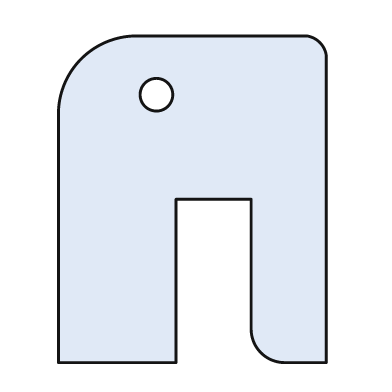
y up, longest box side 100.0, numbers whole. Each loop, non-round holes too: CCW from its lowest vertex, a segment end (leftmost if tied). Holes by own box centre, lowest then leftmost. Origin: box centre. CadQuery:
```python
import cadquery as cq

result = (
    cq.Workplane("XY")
    .moveTo(-41.0, -50.0)
    .lineTo(-5.0, -50.0)
    .lineTo(-5.0, 0.0)
    .lineTo(18.0, 0.0)
    .lineTo(18.0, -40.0)
    .threePointArc((21.0, -47.0), (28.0, -50.0))
    .lineTo(41.0, -50.0)
    .lineTo(41.0, 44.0)
    .threePointArc((39.0, 48.0), (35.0, 50.0))
    .lineTo(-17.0, 50.0)
    .threePointArc((-34.0, 43.0), (-41.0, 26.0))
    .close()
    .moveTo(-11.0, 32.0)
    .circle(5.0)
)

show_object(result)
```